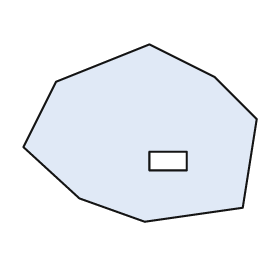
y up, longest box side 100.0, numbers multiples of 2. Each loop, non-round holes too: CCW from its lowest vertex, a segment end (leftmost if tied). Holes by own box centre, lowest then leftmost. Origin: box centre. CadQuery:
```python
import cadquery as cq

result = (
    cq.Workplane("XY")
    .moveTo(2.0, -38.0)
    .lineTo(44.0, -32.0)
    .lineTo(50.0, 6.0)
    .lineTo(32.0, 24.0)
    .lineTo(4.0, 38.0)
    .lineTo(-36.0, 22.0)
    .lineTo(-50.0, -6.0)
    .lineTo(-26.0, -28.0)
    .close()
    .moveTo(4.0, -16.0)
    .lineTo(20.0, -16.0)
    .lineTo(20.0, -8.0)
    .lineTo(4.0, -8.0)
    .close()
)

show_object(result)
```